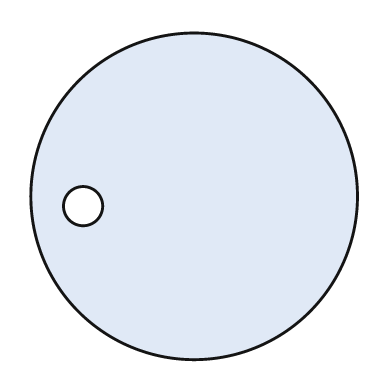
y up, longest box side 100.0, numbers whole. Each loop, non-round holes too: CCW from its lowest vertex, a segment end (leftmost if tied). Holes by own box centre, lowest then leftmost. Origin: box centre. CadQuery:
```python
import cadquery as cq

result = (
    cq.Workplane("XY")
    .moveTo(0.0, 0.0)
    .circle(50.0)
    .moveTo(-34.0, -3.0)
    .circle(6.0)
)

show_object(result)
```